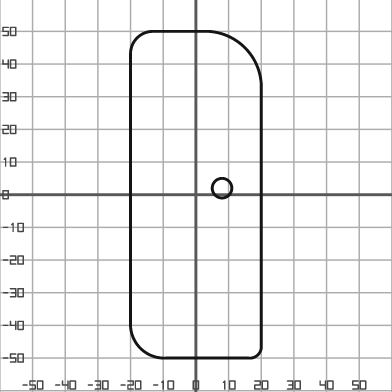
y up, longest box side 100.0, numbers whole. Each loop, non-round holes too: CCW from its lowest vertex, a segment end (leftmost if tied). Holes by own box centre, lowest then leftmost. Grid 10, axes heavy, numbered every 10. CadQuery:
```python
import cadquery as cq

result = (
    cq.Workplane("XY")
    .moveTo(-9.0, -50.0)
    .lineTo(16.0, -50.0)
    .threePointArc((19.0, -49.0), (20.0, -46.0))
    .lineTo(20.0, 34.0)
    .threePointArc((15.0, 45.0), (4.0, 50.0))
    .lineTo(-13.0, 50.0)
    .threePointArc((-18.0, 48.0), (-20.0, 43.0))
    .lineTo(-20.0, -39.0)
    .threePointArc((-17.0, -47.0), (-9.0, -50.0))
    .close()
    .moveTo(8.0, 2.0)
    .circle(3.0)
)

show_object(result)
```